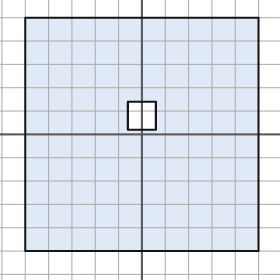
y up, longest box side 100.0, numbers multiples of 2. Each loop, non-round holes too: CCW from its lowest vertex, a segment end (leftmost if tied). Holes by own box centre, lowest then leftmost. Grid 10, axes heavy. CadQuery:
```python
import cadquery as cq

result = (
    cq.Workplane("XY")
    .moveTo(-50.0, -50.0)
    .lineTo(50.0, -50.0)
    .lineTo(50.0, 50.0)
    .lineTo(-50.0, 50.0)
    .close()
    .moveTo(-6.0, 2.0)
    .lineTo(6.0, 2.0)
    .lineTo(6.0, 14.0)
    .lineTo(-6.0, 14.0)
    .close()
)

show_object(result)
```